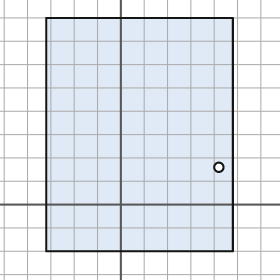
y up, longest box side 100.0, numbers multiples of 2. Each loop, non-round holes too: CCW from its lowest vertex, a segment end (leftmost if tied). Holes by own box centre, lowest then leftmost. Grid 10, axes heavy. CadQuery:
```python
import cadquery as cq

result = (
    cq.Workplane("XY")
    .moveTo(-32.0, -20.0)
    .lineTo(48.0, -20.0)
    .lineTo(48.0, 80.0)
    .lineTo(-32.0, 80.0)
    .close()
    .moveTo(42.0, 16.0)
    .circle(2.0)
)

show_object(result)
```